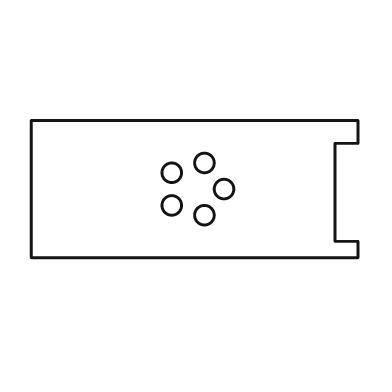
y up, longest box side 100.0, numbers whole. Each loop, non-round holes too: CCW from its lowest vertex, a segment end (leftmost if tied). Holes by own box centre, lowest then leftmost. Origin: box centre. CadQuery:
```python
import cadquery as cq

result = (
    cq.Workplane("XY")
    .moveTo(-50.0, -21.0)
    .lineTo(50.0, -21.0)
    .lineTo(50.0, -16.0)
    .lineTo(43.0, -16.0)
    .lineTo(43.0, 14.0)
    .lineTo(50.0, 14.0)
    .lineTo(50.0, 21.0)
    .lineTo(-50.0, 21.0)
    .close()
    .moveTo(3.0, -8.0)
    .circle(3.0)
    .moveTo(-7.0, -5.0)
    .circle(3.0)
    .moveTo(9.0, 0.0)
    .circle(3.0)
    .moveTo(-7.0, 5.0)
    .circle(3.0)
    .moveTo(3.0, 8.0)
    .circle(3.0)
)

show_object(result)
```